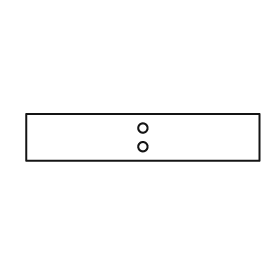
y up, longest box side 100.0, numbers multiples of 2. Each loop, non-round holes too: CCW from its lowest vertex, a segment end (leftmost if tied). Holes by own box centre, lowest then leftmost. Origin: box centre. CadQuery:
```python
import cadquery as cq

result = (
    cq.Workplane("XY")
    .moveTo(-50.0, -10.0)
    .lineTo(50.0, -10.0)
    .lineTo(50.0, 10.0)
    .lineTo(-50.0, 10.0)
    .close()
    .moveTo(0.0, -4.0)
    .circle(2.0)
    .moveTo(0.0, 4.0)
    .circle(2.0)
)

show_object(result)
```